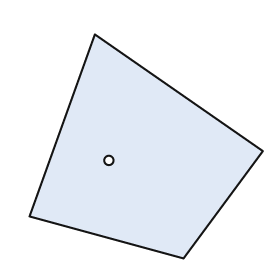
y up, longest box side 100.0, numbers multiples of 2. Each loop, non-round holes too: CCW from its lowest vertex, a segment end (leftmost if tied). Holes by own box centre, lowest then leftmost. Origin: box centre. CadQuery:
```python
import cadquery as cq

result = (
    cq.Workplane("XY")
    .moveTo(16.0, -48.0)
    .lineTo(50.0, -2.0)
    .lineTo(-22.0, 48.0)
    .lineTo(-50.0, -30.0)
    .close()
    .moveTo(-16.0, -6.0)
    .circle(2.0)
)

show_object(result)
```